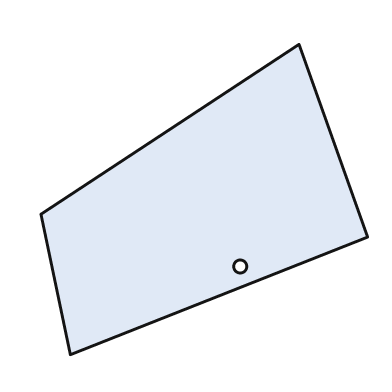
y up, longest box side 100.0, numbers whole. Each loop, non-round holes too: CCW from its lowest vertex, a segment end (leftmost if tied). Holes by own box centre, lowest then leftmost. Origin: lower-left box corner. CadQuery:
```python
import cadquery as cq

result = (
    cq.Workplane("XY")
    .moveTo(9.0, 0.0)
    .lineTo(100.0, 36.0)
    .lineTo(79.0, 95.0)
    .lineTo(0.0, 43.0)
    .close()
    .moveTo(61.0, 27.0)
    .circle(2.0)
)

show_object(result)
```